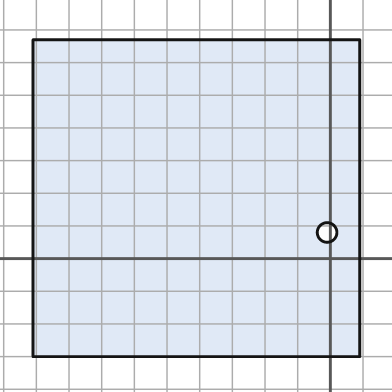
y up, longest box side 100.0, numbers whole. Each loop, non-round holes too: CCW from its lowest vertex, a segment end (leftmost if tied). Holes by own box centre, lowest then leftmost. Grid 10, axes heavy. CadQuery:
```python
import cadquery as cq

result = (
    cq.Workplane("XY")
    .moveTo(-91.0, -30.0)
    .lineTo(9.0, -30.0)
    .lineTo(9.0, 67.0)
    .lineTo(-91.0, 67.0)
    .close()
    .moveTo(-1.0, 8.0)
    .circle(3.0)
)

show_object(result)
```